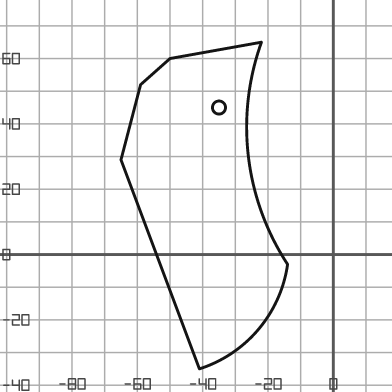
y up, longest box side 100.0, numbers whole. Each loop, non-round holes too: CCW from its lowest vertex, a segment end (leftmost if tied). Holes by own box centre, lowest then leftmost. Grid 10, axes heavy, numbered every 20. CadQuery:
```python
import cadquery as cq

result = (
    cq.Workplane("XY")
    .moveTo(-41.0, -35.0)
    .threePointArc((-23.0, -23.0), (-14.0, -3.0))
    .threePointArc((-26.0, 30.0), (-22.0, 65.0))
    .lineTo(-50.0, 60.0)
    .lineTo(-59.0, 52.0)
    .lineTo(-65.0, 29.0)
    .close()
    .moveTo(-35.0, 45.0)
    .circle(2.0)
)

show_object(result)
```